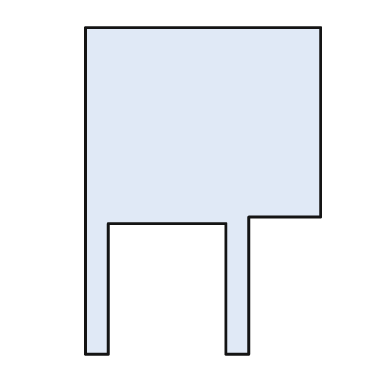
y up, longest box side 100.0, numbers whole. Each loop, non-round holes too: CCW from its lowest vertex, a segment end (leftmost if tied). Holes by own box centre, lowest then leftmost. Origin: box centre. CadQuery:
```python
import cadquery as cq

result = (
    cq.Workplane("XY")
    .moveTo(-36.0, -50.0)
    .lineTo(-29.0, -50.0)
    .lineTo(-29.0, -10.0)
    .lineTo(7.0, -10.0)
    .lineTo(7.0, -50.0)
    .lineTo(14.0, -50.0)
    .lineTo(14.0, -8.0)
    .lineTo(36.0, -8.0)
    .lineTo(36.0, 50.0)
    .lineTo(-36.0, 50.0)
    .close()
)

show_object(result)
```